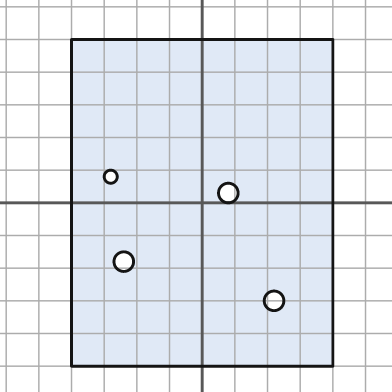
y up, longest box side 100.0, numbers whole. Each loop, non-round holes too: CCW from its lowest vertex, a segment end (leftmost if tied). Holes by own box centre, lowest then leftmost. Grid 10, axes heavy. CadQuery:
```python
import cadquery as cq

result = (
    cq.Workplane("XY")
    .moveTo(-40.0, -50.0)
    .lineTo(40.0, -50.0)
    .lineTo(40.0, 50.0)
    .lineTo(-40.0, 50.0)
    .close()
    .moveTo(22.0, -30.0)
    .circle(3.0)
    .moveTo(-24.0, -18.0)
    .circle(3.0)
    .moveTo(8.0, 3.0)
    .circle(3.0)
    .moveTo(-28.0, 8.0)
    .circle(2.0)
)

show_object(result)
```